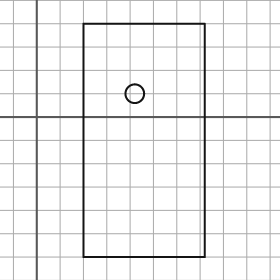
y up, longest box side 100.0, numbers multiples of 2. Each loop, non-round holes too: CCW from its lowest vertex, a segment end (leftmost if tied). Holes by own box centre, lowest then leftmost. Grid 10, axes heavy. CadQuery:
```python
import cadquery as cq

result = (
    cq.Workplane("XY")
    .moveTo(20.0, -60.0)
    .lineTo(72.0, -60.0)
    .lineTo(72.0, 40.0)
    .lineTo(20.0, 40.0)
    .close()
    .moveTo(42.0, 10.0)
    .circle(4.0)
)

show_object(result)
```